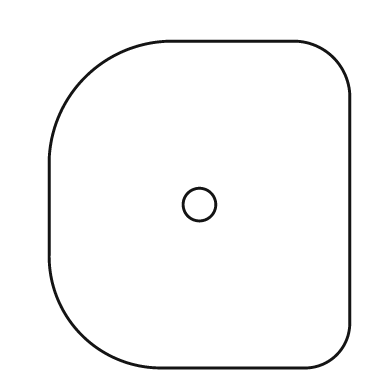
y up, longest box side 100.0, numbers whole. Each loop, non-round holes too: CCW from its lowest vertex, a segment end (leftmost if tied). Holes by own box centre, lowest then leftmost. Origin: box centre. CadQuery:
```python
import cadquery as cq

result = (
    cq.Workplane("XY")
    .moveTo(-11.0, -50.0)
    .lineTo(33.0, -50.0)
    .threePointArc((42.0, -46.0), (46.0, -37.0))
    .lineTo(46.0, 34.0)
    .threePointArc((41.0, 45.0), (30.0, 50.0))
    .lineTo(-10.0, 50.0)
    .threePointArc((-35.0, 39.0), (-46.0, 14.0))
    .lineTo(-46.0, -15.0)
    .threePointArc((-36.0, -40.0), (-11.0, -50.0))
    .close()
    .moveTo(0.0, 0.0)
    .circle(5.0)
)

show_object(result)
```